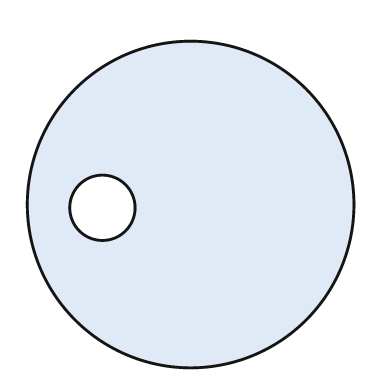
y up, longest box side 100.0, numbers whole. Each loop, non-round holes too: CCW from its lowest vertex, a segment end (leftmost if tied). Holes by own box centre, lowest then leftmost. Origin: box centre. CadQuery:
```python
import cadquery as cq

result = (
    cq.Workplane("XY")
    .moveTo(0.0, 0.0)
    .circle(50.0)
    .moveTo(-27.0, -1.0)
    .circle(10.0)
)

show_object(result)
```